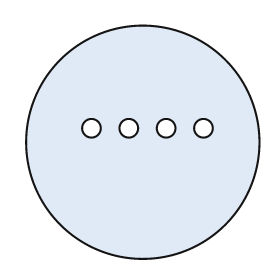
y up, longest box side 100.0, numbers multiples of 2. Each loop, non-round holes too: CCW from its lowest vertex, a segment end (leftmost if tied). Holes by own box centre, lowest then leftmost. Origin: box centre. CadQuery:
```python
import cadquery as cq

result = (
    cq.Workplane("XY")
    .moveTo(0.0, 0.0)
    .circle(50.0)
    .moveTo(-22.0, 6.0)
    .circle(4.0)
    .moveTo(-6.0, 6.0)
    .circle(4.0)
    .moveTo(10.0, 6.0)
    .circle(4.0)
    .moveTo(26.0, 6.0)
    .circle(4.0)
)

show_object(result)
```